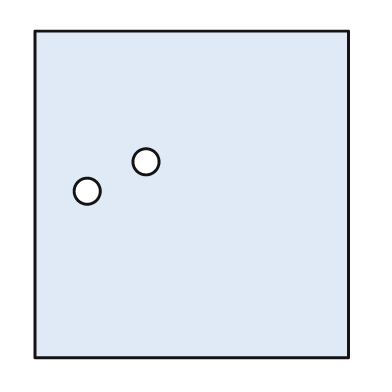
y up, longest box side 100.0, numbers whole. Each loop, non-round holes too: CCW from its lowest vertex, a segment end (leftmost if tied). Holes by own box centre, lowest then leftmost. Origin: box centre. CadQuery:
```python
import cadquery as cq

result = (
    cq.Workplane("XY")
    .moveTo(-48.0, -50.0)
    .lineTo(48.0, -50.0)
    .lineTo(48.0, 50.0)
    .lineTo(-48.0, 50.0)
    .close()
    .moveTo(-32.0, 1.0)
    .circle(4.0)
    .moveTo(-14.0, 10.0)
    .circle(4.0)
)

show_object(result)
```